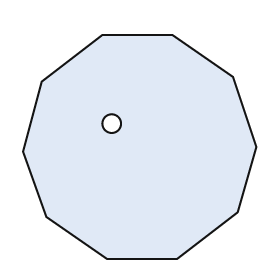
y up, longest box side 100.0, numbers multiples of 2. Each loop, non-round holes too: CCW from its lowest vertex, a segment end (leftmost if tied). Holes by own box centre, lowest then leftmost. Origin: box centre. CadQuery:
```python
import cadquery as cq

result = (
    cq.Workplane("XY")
    .moveTo(-14.0, -48.0)
    .lineTo(16.0, -48.0)
    .lineTo(42.0, -28.0)
    .lineTo(50.0, 0.0)
    .lineTo(40.0, 30.0)
    .lineTo(14.0, 48.0)
    .lineTo(-16.0, 48.0)
    .lineTo(-42.0, 28.0)
    .lineTo(-50.0, -2.0)
    .lineTo(-40.0, -30.0)
    .close()
    .moveTo(-12.0, 10.0)
    .circle(4.0)
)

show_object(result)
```